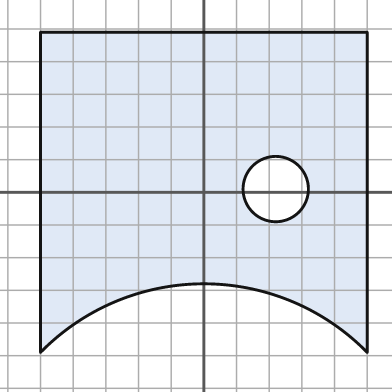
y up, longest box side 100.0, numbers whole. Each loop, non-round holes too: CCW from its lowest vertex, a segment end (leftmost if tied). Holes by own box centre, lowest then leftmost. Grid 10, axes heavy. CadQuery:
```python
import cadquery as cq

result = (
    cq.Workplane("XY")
    .moveTo(-50.0, -49.0)
    .threePointArc((0.0, -28.0), (50.0, -49.0))
    .lineTo(50.0, 49.0)
    .lineTo(-50.0, 49.0)
    .close()
    .moveTo(22.0, 1.0)
    .circle(10.0)
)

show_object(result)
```